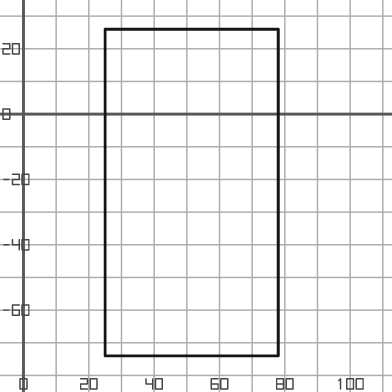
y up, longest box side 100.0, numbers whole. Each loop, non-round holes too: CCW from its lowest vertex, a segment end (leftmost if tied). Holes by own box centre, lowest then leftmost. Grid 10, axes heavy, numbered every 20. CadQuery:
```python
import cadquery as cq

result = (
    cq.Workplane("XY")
    .moveTo(25.0, -74.0)
    .lineTo(78.0, -74.0)
    .lineTo(78.0, 26.0)
    .lineTo(25.0, 26.0)
    .close()
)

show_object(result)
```